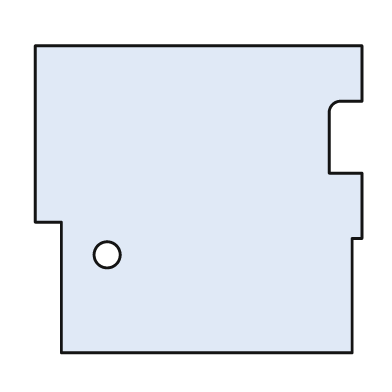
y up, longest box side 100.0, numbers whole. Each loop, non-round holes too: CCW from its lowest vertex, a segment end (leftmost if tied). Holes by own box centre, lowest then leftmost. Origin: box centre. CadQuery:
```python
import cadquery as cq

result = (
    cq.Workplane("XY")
    .moveTo(-42.0, -47.0)
    .lineTo(47.0, -47.0)
    .lineTo(47.0, -12.0)
    .lineTo(50.0, -12.0)
    .lineTo(50.0, 8.0)
    .lineTo(40.0, 8.0)
    .lineTo(40.0, 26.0)
    .threePointArc((41.0, 29.0), (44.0, 30.0))
    .lineTo(50.0, 30.0)
    .lineTo(50.0, 47.0)
    .lineTo(-50.0, 47.0)
    .lineTo(-50.0, -7.0)
    .lineTo(-42.0, -7.0)
    .close()
    .moveTo(-28.0, -17.0)
    .circle(4.0)
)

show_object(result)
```